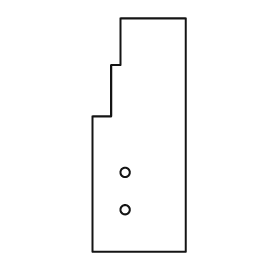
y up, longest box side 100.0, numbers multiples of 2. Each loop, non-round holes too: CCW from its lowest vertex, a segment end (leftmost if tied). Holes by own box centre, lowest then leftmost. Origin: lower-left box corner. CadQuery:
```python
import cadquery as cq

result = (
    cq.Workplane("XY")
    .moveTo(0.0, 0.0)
    .lineTo(40.0, 0.0)
    .lineTo(40.0, 100.0)
    .lineTo(12.0, 100.0)
    .lineTo(12.0, 80.0)
    .lineTo(8.0, 80.0)
    .lineTo(8.0, 58.0)
    .lineTo(0.0, 58.0)
    .close()
    .moveTo(14.0, 18.0)
    .circle(2.0)
    .moveTo(14.0, 34.0)
    .circle(2.0)
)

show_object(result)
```